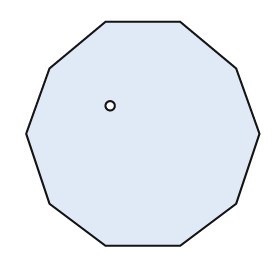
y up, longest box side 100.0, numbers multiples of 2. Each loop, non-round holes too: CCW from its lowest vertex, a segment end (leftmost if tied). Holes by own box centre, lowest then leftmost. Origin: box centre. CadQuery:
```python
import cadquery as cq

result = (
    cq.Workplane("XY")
    .moveTo(-16.0, -48.0)
    .lineTo(16.0, -48.0)
    .lineTo(40.0, -30.0)
    .lineTo(50.0, 0.0)
    .lineTo(40.0, 28.0)
    .lineTo(16.0, 48.0)
    .lineTo(-16.0, 48.0)
    .lineTo(-40.0, 28.0)
    .lineTo(-50.0, 0.0)
    .lineTo(-40.0, -30.0)
    .close()
    .moveTo(-14.0, 12.0)
    .circle(2.0)
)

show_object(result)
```